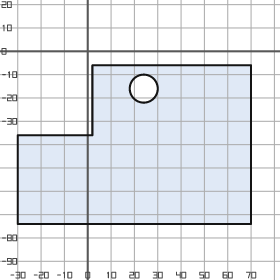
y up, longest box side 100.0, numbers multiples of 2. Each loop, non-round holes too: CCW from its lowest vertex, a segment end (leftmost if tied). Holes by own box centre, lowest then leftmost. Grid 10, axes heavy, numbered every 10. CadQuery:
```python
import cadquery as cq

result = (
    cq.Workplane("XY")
    .moveTo(-30.0, -74.0)
    .lineTo(70.0, -74.0)
    .lineTo(70.0, -6.0)
    .lineTo(2.0, -6.0)
    .lineTo(2.0, -36.0)
    .lineTo(-30.0, -36.0)
    .close()
    .moveTo(24.0, -16.0)
    .circle(6.0)
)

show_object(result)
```